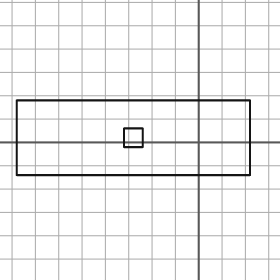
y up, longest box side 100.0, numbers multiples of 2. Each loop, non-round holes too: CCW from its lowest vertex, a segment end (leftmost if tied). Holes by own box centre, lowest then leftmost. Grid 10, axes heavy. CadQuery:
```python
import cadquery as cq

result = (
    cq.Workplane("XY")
    .moveTo(-78.0, -14.0)
    .lineTo(22.0, -14.0)
    .lineTo(22.0, 18.0)
    .lineTo(-78.0, 18.0)
    .close()
    .moveTo(-32.0, -2.0)
    .lineTo(-24.0, -2.0)
    .lineTo(-24.0, 6.0)
    .lineTo(-32.0, 6.0)
    .close()
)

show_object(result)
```